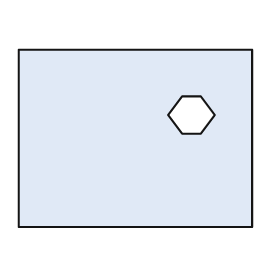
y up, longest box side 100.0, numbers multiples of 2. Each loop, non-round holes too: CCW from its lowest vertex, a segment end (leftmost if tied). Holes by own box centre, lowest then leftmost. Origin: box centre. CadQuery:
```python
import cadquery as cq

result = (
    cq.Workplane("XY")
    .moveTo(-50.0, -38.0)
    .lineTo(50.0, -38.0)
    .lineTo(50.0, 38.0)
    .lineTo(-50.0, 38.0)
    .close()
    .moveTo(20.0, 2.0)
    .lineTo(28.0, 2.0)
    .lineTo(34.0, 10.0)
    .lineTo(28.0, 18.0)
    .lineTo(20.0, 18.0)
    .lineTo(14.0, 10.0)
    .close()
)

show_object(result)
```